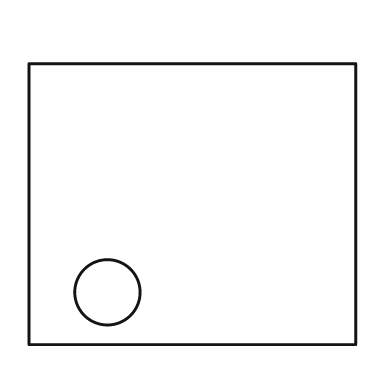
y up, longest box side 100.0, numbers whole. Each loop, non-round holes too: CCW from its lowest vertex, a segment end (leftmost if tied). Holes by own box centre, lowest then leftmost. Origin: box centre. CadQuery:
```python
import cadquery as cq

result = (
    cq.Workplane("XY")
    .moveTo(-50.0, -43.0)
    .lineTo(50.0, -43.0)
    .lineTo(50.0, 43.0)
    .lineTo(-50.0, 43.0)
    .close()
    .moveTo(-26.0, -27.0)
    .circle(10.0)
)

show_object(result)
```